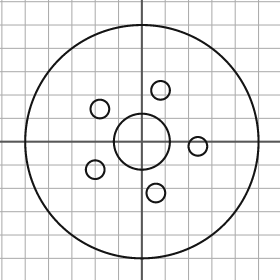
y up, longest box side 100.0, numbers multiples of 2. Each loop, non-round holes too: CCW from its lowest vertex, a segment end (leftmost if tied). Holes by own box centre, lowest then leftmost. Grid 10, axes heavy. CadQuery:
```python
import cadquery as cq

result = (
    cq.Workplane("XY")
    .moveTo(0.0, 0.0)
    .circle(50.0)
    .moveTo(6.0, -22.0)
    .circle(4.0)
    .moveTo(-20.0, -12.0)
    .circle(4.0)
    .moveTo(24.0, -2.0)
    .circle(4.0)
    .moveTo(0.0, 0.0)
    .circle(12.0)
    .moveTo(-18.0, 14.0)
    .circle(4.0)
    .moveTo(8.0, 22.0)
    .circle(4.0)
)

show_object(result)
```